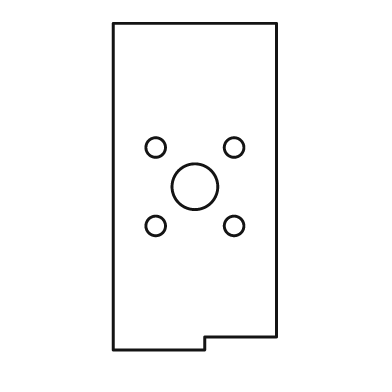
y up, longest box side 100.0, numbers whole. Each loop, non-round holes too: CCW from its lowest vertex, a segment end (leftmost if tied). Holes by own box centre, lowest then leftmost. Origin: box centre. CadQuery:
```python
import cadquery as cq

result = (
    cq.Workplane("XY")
    .moveTo(-25.0, -50.0)
    .lineTo(3.0, -50.0)
    .lineTo(3.0, -46.0)
    .lineTo(25.0, -46.0)
    .lineTo(25.0, 50.0)
    .lineTo(-25.0, 50.0)
    .close()
    .moveTo(-12.0, -12.0)
    .circle(3.0)
    .moveTo(12.0, -12.0)
    .circle(3.0)
    .moveTo(0.0, 0.0)
    .circle(7.0)
    .moveTo(-12.0, 12.0)
    .circle(3.0)
    .moveTo(12.0, 12.0)
    .circle(3.0)
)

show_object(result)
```